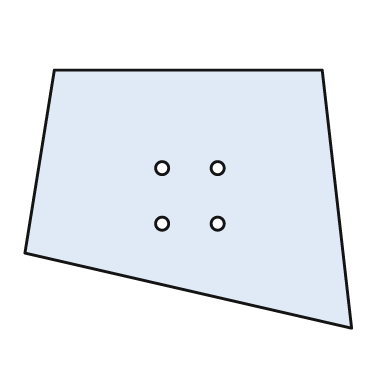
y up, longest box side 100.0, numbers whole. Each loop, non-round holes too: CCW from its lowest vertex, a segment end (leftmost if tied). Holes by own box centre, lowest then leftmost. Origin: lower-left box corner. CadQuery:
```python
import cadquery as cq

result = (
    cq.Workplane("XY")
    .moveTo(100.0, 0.0)
    .lineTo(91.0, 79.0)
    .lineTo(9.0, 79.0)
    .lineTo(0.0, 23.0)
    .close()
    .moveTo(42.0, 32.0)
    .circle(2.0)
    .moveTo(59.0, 32.0)
    .circle(2.0)
    .moveTo(42.0, 49.0)
    .circle(2.0)
    .moveTo(59.0, 49.0)
    .circle(2.0)
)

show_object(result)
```